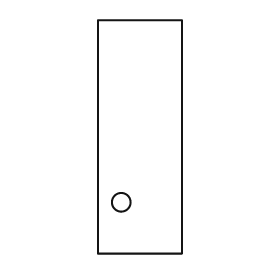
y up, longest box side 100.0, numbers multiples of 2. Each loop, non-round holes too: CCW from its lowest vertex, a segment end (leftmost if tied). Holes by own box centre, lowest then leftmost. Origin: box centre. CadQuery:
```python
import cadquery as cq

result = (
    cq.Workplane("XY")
    .moveTo(-18.0, -50.0)
    .lineTo(18.0, -50.0)
    .lineTo(18.0, 50.0)
    .lineTo(-18.0, 50.0)
    .close()
    .moveTo(-8.0, -28.0)
    .circle(4.0)
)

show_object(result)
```